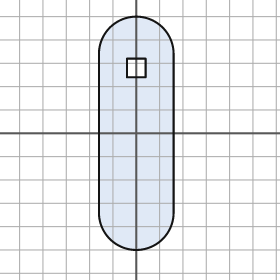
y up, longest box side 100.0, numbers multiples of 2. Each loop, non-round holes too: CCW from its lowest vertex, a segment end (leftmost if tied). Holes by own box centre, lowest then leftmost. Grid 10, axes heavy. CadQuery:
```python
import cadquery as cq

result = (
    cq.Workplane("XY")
    .moveTo(-16.0, -34.0)
    .threePointArc((0.0, -50.0), (16.0, -34.0))
    .lineTo(16.0, 34.0)
    .threePointArc((0.0, 50.0), (-16.0, 34.0))
    .close()
    .moveTo(-4.0, 24.0)
    .lineTo(4.0, 24.0)
    .lineTo(4.0, 32.0)
    .lineTo(-4.0, 32.0)
    .close()
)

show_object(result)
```